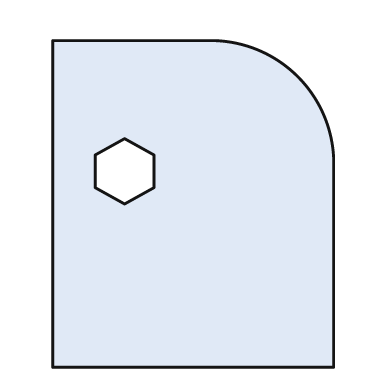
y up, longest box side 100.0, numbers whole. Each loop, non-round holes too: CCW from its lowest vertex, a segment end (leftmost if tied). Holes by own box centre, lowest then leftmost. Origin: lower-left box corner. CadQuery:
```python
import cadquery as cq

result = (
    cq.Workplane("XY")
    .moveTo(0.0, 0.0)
    .lineTo(86.0, 0.0)
    .lineTo(86.0, 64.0)
    .threePointArc((75.0, 89.0), (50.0, 100.0))
    .lineTo(0.0, 100.0)
    .close()
    .moveTo(22.0, 50.0)
    .lineTo(31.0, 55.0)
    .lineTo(31.0, 65.0)
    .lineTo(22.0, 70.0)
    .lineTo(13.0, 65.0)
    .lineTo(13.0, 55.0)
    .close()
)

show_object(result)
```